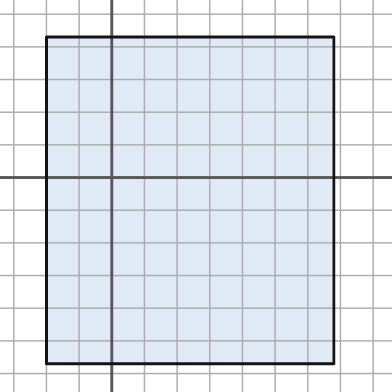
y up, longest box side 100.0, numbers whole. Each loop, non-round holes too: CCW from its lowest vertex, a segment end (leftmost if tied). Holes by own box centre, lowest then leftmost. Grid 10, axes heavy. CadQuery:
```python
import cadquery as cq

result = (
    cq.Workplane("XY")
    .moveTo(-20.0, -57.0)
    .lineTo(68.0, -57.0)
    .lineTo(68.0, 43.0)
    .lineTo(-20.0, 43.0)
    .close()
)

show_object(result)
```